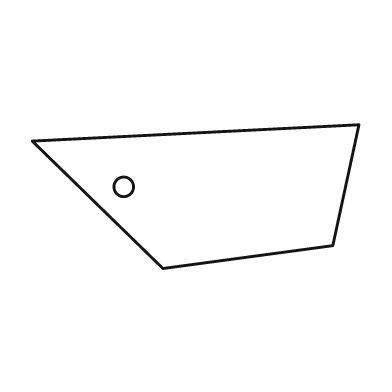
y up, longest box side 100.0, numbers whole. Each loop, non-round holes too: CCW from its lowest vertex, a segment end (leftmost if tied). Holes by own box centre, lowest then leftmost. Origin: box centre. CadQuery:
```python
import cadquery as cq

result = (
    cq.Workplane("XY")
    .moveTo(-10.0, -22.0)
    .lineTo(42.0, -15.0)
    .lineTo(50.0, 22.0)
    .lineTo(-50.0, 17.0)
    .close()
    .moveTo(-22.0, 3.0)
    .circle(3.0)
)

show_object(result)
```